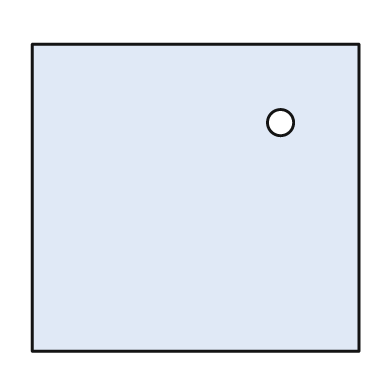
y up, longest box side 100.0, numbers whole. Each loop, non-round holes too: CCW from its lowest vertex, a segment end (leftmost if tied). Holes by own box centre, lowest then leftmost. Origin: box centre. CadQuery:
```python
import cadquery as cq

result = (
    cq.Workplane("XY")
    .moveTo(-50.0, -47.0)
    .lineTo(50.0, -47.0)
    .lineTo(50.0, 47.0)
    .lineTo(-50.0, 47.0)
    .close()
    .moveTo(26.0, 23.0)
    .circle(4.0)
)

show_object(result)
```